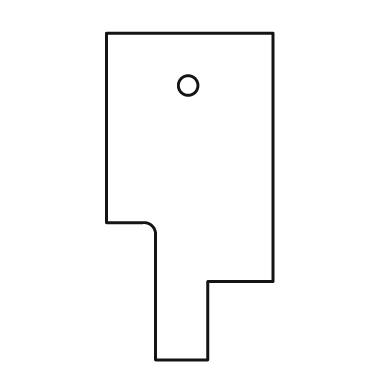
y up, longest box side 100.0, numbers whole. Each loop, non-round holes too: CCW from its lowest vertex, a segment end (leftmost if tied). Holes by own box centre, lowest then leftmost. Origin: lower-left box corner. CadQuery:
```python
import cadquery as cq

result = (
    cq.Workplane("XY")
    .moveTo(15.0, 0.0)
    .lineTo(31.0, 0.0)
    .lineTo(31.0, 24.0)
    .lineTo(51.0, 24.0)
    .lineTo(51.0, 100.0)
    .lineTo(0.0, 100.0)
    .lineTo(0.0, 42.0)
    .lineTo(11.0, 42.0)
    .threePointArc((14.0, 41.0), (15.0, 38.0))
    .close()
    .moveTo(25.0, 84.0)
    .circle(3.0)
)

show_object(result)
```